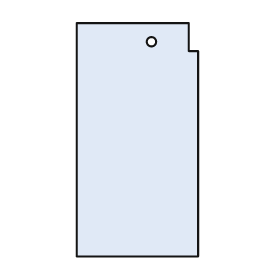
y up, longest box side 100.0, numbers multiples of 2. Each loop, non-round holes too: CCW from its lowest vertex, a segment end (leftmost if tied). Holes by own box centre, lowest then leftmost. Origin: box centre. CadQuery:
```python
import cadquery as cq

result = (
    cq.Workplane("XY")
    .moveTo(-26.0, -50.0)
    .lineTo(26.0, -50.0)
    .lineTo(26.0, 38.0)
    .lineTo(22.0, 38.0)
    .lineTo(22.0, 50.0)
    .lineTo(-26.0, 50.0)
    .close()
    .moveTo(6.0, 42.0)
    .circle(2.0)
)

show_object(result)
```